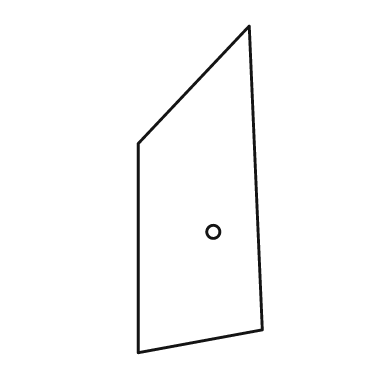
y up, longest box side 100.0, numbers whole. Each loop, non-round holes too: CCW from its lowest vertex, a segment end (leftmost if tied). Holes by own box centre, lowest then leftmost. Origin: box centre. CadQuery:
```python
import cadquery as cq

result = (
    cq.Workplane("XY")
    .moveTo(-19.0, -50.0)
    .lineTo(19.0, -43.0)
    .lineTo(15.0, 50.0)
    .lineTo(-19.0, 14.0)
    .close()
    .moveTo(4.0, -13.0)
    .circle(2.0)
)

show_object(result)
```